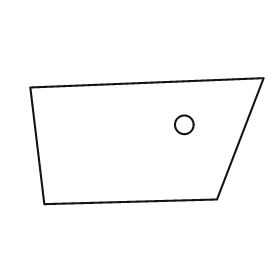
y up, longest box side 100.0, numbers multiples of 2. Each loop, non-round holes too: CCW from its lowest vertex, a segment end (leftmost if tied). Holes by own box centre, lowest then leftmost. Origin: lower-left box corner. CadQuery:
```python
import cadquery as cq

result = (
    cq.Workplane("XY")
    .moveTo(6.0, 0.0)
    .lineTo(80.0, 2.0)
    .lineTo(100.0, 54.0)
    .lineTo(0.0, 50.0)
    .close()
    .moveTo(66.0, 34.0)
    .circle(4.0)
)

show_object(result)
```